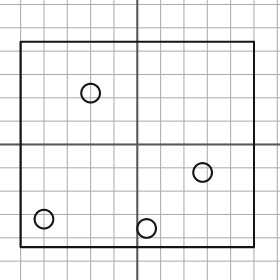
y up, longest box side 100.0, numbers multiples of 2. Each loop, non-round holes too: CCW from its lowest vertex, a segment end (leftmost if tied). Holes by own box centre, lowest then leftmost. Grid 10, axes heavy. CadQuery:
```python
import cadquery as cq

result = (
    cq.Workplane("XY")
    .moveTo(-50.0, -44.0)
    .lineTo(50.0, -44.0)
    .lineTo(50.0, 44.0)
    .lineTo(-50.0, 44.0)
    .close()
    .moveTo(4.0, -36.0)
    .circle(4.0)
    .moveTo(-40.0, -32.0)
    .circle(4.0)
    .moveTo(28.0, -12.0)
    .circle(4.0)
    .moveTo(-20.0, 22.0)
    .circle(4.0)
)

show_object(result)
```